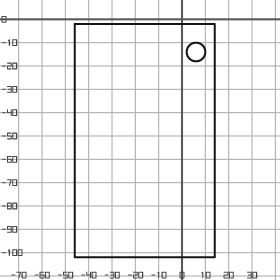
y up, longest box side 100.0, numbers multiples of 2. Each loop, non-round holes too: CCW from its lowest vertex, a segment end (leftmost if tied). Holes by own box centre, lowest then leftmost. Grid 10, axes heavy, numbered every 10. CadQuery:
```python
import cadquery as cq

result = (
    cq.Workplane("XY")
    .moveTo(-46.0, -102.0)
    .lineTo(14.0, -102.0)
    .lineTo(14.0, -2.0)
    .lineTo(-46.0, -2.0)
    .close()
    .moveTo(6.0, -14.0)
    .circle(4.0)
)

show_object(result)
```